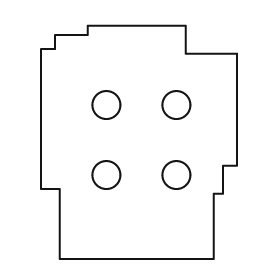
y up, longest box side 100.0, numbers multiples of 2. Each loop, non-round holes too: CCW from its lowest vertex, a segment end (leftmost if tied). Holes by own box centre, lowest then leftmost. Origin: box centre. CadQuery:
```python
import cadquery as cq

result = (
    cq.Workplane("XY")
    .moveTo(-34.0, -50.0)
    .lineTo(32.0, -50.0)
    .lineTo(32.0, -22.0)
    .lineTo(36.0, -22.0)
    .lineTo(36.0, -10.0)
    .lineTo(42.0, -10.0)
    .lineTo(42.0, 38.0)
    .lineTo(20.0, 38.0)
    .lineTo(20.0, 50.0)
    .lineTo(-22.0, 50.0)
    .lineTo(-22.0, 46.0)
    .lineTo(-36.0, 46.0)
    .lineTo(-36.0, 40.0)
    .lineTo(-42.0, 40.0)
    .lineTo(-42.0, -20.0)
    .lineTo(-34.0, -20.0)
    .close()
    .moveTo(-14.0, -14.0)
    .circle(6.0)
    .moveTo(16.0, -14.0)
    .circle(6.0)
    .moveTo(-14.0, 16.0)
    .circle(6.0)
    .moveTo(16.0, 16.0)
    .circle(6.0)
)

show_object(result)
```